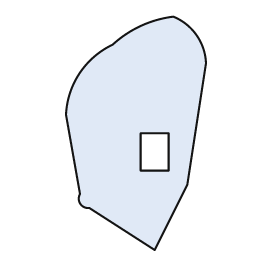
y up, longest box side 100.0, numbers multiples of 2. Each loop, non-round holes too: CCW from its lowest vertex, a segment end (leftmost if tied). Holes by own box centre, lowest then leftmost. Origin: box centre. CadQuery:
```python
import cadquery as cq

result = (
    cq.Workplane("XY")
    .moveTo(8.0, -50.0)
    .lineTo(22.0, -22.0)
    .lineTo(30.0, 30.0)
    .threePointArc((26.0, 42.0), (16.0, 50.0))
    .threePointArc((2.0, 46.0), (-10.0, 38.0))
    .threePointArc((-24.0, 26.0), (-30.0, 8.0))
    .lineTo(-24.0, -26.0)
    .threePointArc((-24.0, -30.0), (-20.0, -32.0))
    .close()
    .moveTo(2.0, -16.0)
    .lineTo(14.0, -16.0)
    .lineTo(14.0, 0.0)
    .lineTo(2.0, 0.0)
    .close()
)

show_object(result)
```